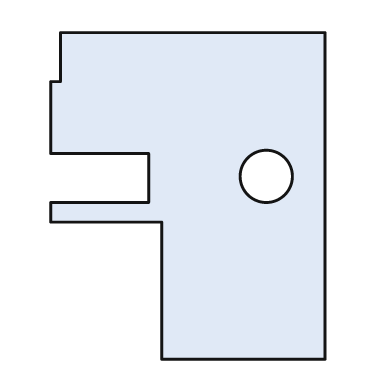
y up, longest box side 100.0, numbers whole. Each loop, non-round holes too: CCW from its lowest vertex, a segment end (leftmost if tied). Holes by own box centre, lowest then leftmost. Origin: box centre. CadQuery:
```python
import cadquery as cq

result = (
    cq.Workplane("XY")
    .moveTo(-8.0, -50.0)
    .lineTo(42.0, -50.0)
    .lineTo(42.0, 50.0)
    .lineTo(-39.0, 50.0)
    .lineTo(-39.0, 35.0)
    .lineTo(-42.0, 35.0)
    .lineTo(-42.0, 13.0)
    .lineTo(-12.0, 13.0)
    .lineTo(-12.0, -2.0)
    .lineTo(-42.0, -2.0)
    .lineTo(-42.0, -8.0)
    .lineTo(-8.0, -8.0)
    .close()
    .moveTo(24.0, 6.0)
    .circle(8.0)
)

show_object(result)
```